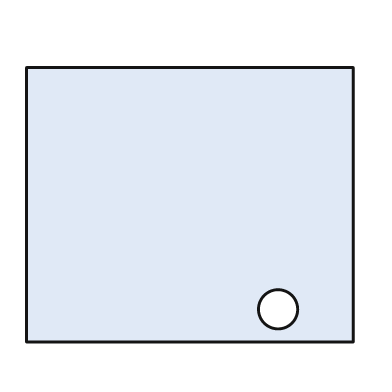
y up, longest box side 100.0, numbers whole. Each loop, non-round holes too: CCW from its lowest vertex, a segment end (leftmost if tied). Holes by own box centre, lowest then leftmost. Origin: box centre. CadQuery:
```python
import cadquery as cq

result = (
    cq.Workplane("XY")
    .moveTo(-50.0, -42.0)
    .lineTo(50.0, -42.0)
    .lineTo(50.0, 42.0)
    .lineTo(-50.0, 42.0)
    .close()
    .moveTo(27.0, -32.0)
    .circle(6.0)
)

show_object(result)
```